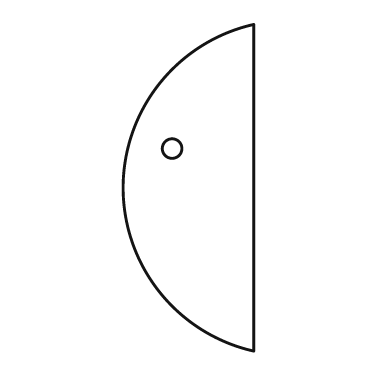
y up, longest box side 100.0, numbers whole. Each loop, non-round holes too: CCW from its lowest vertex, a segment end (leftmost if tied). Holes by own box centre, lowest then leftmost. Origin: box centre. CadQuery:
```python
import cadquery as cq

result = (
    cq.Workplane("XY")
    .moveTo(20.0, -50.0)
    .lineTo(20.0, 50.0)
    .threePointArc((-20.0, 0.0), (20.0, -50.0))
    .close()
    .moveTo(-5.0, 12.0)
    .circle(3.0)
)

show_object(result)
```